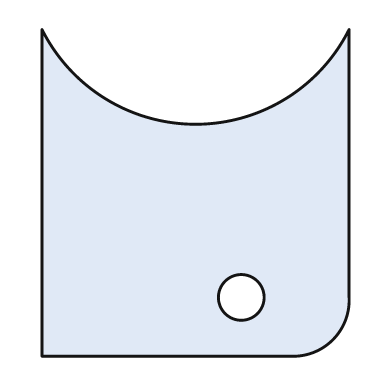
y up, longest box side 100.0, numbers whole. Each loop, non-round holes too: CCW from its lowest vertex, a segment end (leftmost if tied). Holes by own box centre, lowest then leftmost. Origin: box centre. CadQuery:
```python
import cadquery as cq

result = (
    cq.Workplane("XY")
    .moveTo(-47.0, -50.0)
    .lineTo(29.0, -50.0)
    .threePointArc((42.0, -45.0), (47.0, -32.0))
    .lineTo(47.0, 50.0)
    .threePointArc((0.0, 21.0), (-47.0, 50.0))
    .close()
    .moveTo(14.0, -32.0)
    .circle(7.0)
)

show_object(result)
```